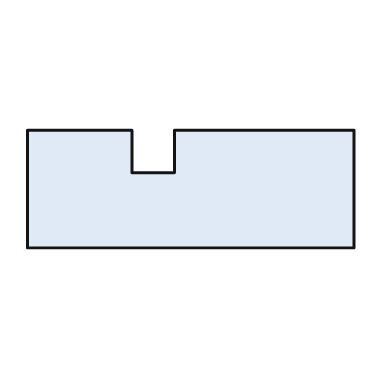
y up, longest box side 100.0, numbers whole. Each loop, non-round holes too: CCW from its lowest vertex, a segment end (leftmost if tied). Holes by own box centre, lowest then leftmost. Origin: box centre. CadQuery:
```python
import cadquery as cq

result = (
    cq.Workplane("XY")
    .moveTo(-50.0, -18.0)
    .lineTo(50.0, -18.0)
    .lineTo(50.0, 18.0)
    .lineTo(-5.0, 18.0)
    .lineTo(-5.0, 5.0)
    .lineTo(-18.0, 5.0)
    .lineTo(-18.0, 18.0)
    .lineTo(-50.0, 18.0)
    .close()
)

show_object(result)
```